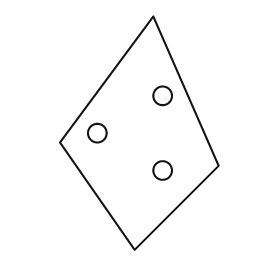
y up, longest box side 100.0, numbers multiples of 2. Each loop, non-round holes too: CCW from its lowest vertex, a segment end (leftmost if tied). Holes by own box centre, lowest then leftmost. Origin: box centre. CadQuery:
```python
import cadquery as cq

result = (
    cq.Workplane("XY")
    .moveTo(-2.0, -50.0)
    .lineTo(34.0, -14.0)
    .lineTo(6.0, 50.0)
    .lineTo(-34.0, -4.0)
    .close()
    .moveTo(10.0, -16.0)
    .circle(4.0)
    .moveTo(-18.0, 0.0)
    .circle(4.0)
    .moveTo(10.0, 16.0)
    .circle(4.0)
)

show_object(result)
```